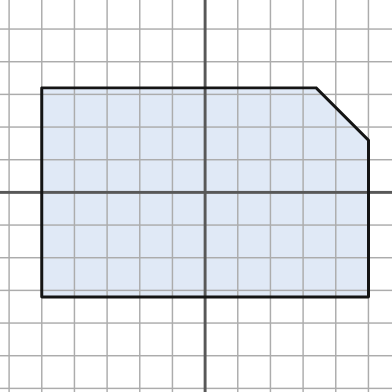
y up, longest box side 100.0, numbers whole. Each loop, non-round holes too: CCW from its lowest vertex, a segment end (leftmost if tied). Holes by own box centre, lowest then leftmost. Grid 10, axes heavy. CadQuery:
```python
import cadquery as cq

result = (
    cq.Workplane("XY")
    .moveTo(-50.0, -32.0)
    .lineTo(50.0, -32.0)
    .lineTo(50.0, 16.0)
    .lineTo(34.0, 32.0)
    .lineTo(-50.0, 32.0)
    .close()
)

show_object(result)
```